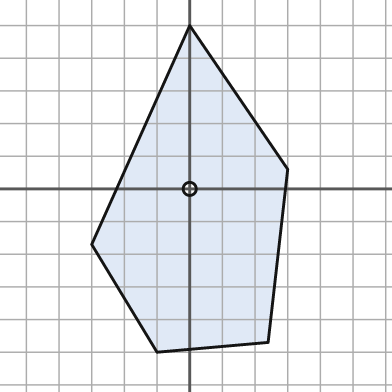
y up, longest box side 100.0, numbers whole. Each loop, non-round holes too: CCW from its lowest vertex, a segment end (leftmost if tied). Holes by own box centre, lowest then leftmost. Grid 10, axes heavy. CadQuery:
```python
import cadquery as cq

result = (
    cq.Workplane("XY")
    .moveTo(-10.0, -50.0)
    .lineTo(24.0, -47.0)
    .lineTo(30.0, 6.0)
    .lineTo(0.0, 50.0)
    .lineTo(-30.0, -17.0)
    .close()
    .moveTo(0.0, 0.0)
    .circle(2.0)
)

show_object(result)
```